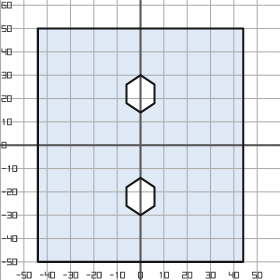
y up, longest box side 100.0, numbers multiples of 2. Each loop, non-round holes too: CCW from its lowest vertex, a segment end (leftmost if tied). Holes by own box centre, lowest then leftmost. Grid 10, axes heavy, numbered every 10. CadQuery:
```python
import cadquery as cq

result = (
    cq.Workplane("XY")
    .moveTo(-44.0, -50.0)
    .lineTo(44.0, -50.0)
    .lineTo(44.0, 50.0)
    .lineTo(-44.0, 50.0)
    .close()
    .moveTo(0.0, -30.0)
    .lineTo(6.0, -26.0)
    .lineTo(6.0, -18.0)
    .lineTo(0.0, -14.0)
    .lineTo(-6.0, -18.0)
    .lineTo(-6.0, -26.0)
    .close()
    .moveTo(0.0, 14.0)
    .lineTo(6.0, 18.0)
    .lineTo(6.0, 26.0)
    .lineTo(0.0, 30.0)
    .lineTo(-6.0, 26.0)
    .lineTo(-6.0, 18.0)
    .close()
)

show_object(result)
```